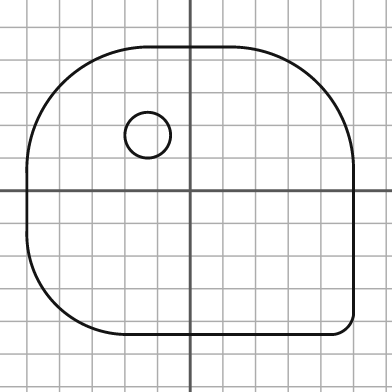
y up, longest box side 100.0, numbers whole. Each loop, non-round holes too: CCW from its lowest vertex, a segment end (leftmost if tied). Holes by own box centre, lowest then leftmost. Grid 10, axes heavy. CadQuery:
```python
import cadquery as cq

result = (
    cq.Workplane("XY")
    .moveTo(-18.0, -44.0)
    .lineTo(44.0, -44.0)
    .threePointArc((48.0, -42.0), (50.0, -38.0))
    .lineTo(50.0, 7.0)
    .threePointArc((39.0, 33.0), (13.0, 44.0))
    .lineTo(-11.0, 44.0)
    .threePointArc((-39.0, 33.0), (-50.0, 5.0))
    .lineTo(-50.0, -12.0)
    .threePointArc((-41.0, -35.0), (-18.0, -44.0))
    .close()
    .moveTo(-13.0, 17.0)
    .circle(7.0)
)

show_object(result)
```